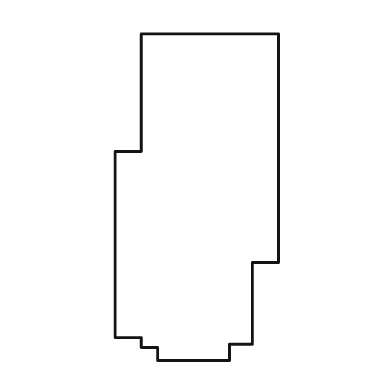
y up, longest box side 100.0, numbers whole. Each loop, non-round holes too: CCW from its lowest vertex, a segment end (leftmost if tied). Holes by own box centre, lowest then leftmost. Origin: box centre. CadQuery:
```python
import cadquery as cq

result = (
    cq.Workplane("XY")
    .moveTo(-12.0, -50.0)
    .lineTo(10.0, -50.0)
    .lineTo(10.0, -45.0)
    .lineTo(17.0, -45.0)
    .lineTo(17.0, -20.0)
    .lineTo(25.0, -20.0)
    .lineTo(25.0, 50.0)
    .lineTo(-17.0, 50.0)
    .lineTo(-17.0, 14.0)
    .lineTo(-25.0, 14.0)
    .lineTo(-25.0, -43.0)
    .lineTo(-17.0, -43.0)
    .lineTo(-17.0, -46.0)
    .lineTo(-12.0, -46.0)
    .close()
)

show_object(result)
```